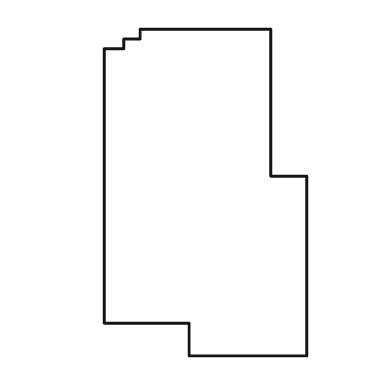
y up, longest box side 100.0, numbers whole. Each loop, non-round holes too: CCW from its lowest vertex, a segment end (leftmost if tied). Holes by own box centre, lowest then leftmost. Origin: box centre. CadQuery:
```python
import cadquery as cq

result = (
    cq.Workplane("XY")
    .moveTo(-5.0, -50.0)
    .lineTo(31.0, -50.0)
    .lineTo(31.0, 5.0)
    .lineTo(20.0, 5.0)
    .lineTo(20.0, 50.0)
    .lineTo(-20.0, 50.0)
    .lineTo(-20.0, 47.0)
    .lineTo(-25.0, 47.0)
    .lineTo(-25.0, 44.0)
    .lineTo(-31.0, 44.0)
    .lineTo(-31.0, -40.0)
    .lineTo(-5.0, -40.0)
    .close()
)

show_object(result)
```